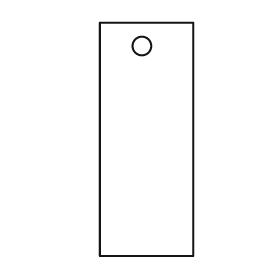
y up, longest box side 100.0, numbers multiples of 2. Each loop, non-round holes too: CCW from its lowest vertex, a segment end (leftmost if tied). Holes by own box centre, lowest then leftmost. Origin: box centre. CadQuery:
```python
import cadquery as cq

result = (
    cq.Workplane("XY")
    .moveTo(-20.0, -50.0)
    .lineTo(20.0, -50.0)
    .lineTo(20.0, 50.0)
    .lineTo(-20.0, 50.0)
    .close()
    .moveTo(-2.0, 40.0)
    .circle(4.0)
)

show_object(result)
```